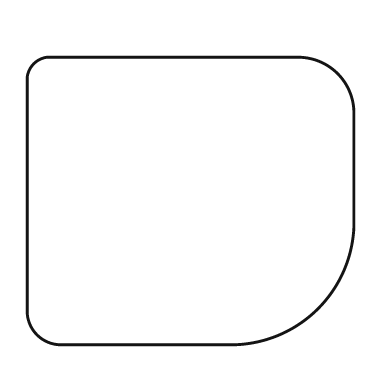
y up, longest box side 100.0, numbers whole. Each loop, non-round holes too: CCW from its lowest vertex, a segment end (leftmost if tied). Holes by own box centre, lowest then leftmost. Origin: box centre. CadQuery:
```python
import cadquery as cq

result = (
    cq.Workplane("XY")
    .moveTo(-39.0, -44.0)
    .lineTo(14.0, -44.0)
    .threePointArc((39.0, -33.0), (50.0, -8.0))
    .lineTo(50.0, 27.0)
    .threePointArc((45.0, 39.0), (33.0, 44.0))
    .lineTo(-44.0, 44.0)
    .threePointArc((-48.0, 42.0), (-50.0, 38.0))
    .lineTo(-50.0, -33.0)
    .threePointArc((-47.0, -41.0), (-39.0, -44.0))
    .close()
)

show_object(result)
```